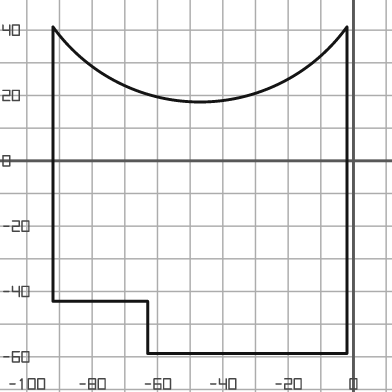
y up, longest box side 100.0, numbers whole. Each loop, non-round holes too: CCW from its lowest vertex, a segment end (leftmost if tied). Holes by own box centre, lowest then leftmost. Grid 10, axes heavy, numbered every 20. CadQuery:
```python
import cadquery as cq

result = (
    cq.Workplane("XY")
    .moveTo(-63.0, -59.0)
    .lineTo(-2.0, -59.0)
    .lineTo(-2.0, 41.0)
    .threePointArc((-47.0, 18.0), (-92.0, 41.0))
    .lineTo(-92.0, -43.0)
    .lineTo(-63.0, -43.0)
    .close()
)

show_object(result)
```